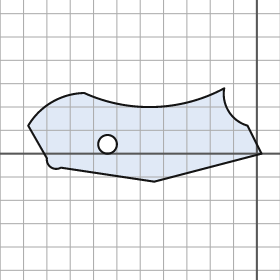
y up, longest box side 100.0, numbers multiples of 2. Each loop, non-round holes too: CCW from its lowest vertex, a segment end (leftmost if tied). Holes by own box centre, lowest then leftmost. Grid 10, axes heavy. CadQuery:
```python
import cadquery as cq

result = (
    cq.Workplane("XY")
    .moveTo(-44.0, -12.0)
    .lineTo(2.0, 0.0)
    .lineTo(-4.0, 12.0)
    .threePointArc((-12.0, 18.0), (-14.0, 28.0))
    .threePointArc((-44.0, 20.0), (-74.0, 26.0))
    .threePointArc((-88.0, 22.0), (-98.0, 12.0))
    .lineTo(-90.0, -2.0)
    .threePointArc((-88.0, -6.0), (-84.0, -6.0))
    .close()
    .moveTo(-64.0, 4.0)
    .circle(4.0)
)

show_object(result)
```